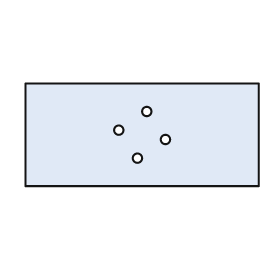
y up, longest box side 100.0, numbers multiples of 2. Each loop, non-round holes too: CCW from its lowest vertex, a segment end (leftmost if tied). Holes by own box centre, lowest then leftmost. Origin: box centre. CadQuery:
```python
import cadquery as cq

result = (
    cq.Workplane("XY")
    .moveTo(-50.0, -22.0)
    .lineTo(50.0, -22.0)
    .lineTo(50.0, 22.0)
    .lineTo(-50.0, 22.0)
    .close()
    .moveTo(-2.0, -10.0)
    .circle(2.0)
    .moveTo(10.0, -2.0)
    .circle(2.0)
    .moveTo(-10.0, 2.0)
    .circle(2.0)
    .moveTo(2.0, 10.0)
    .circle(2.0)
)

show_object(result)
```